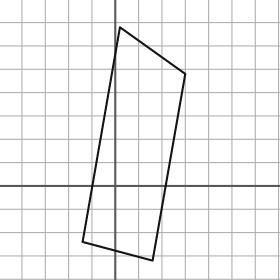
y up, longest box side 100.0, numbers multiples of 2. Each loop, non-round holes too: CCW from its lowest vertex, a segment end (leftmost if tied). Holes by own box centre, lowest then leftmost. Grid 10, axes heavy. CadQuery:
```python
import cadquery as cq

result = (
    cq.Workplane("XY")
    .moveTo(16.0, -32.0)
    .lineTo(30.0, 48.0)
    .lineTo(2.0, 68.0)
    .lineTo(-14.0, -24.0)
    .close()
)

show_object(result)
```